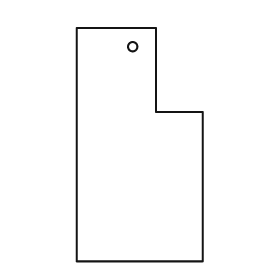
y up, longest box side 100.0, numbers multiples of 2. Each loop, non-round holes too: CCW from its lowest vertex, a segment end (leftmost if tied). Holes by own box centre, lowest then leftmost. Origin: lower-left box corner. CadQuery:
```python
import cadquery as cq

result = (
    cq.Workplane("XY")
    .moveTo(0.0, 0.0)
    .lineTo(54.0, 0.0)
    .lineTo(54.0, 64.0)
    .lineTo(34.0, 64.0)
    .lineTo(34.0, 100.0)
    .lineTo(0.0, 100.0)
    .close()
    .moveTo(24.0, 92.0)
    .circle(2.0)
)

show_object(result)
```